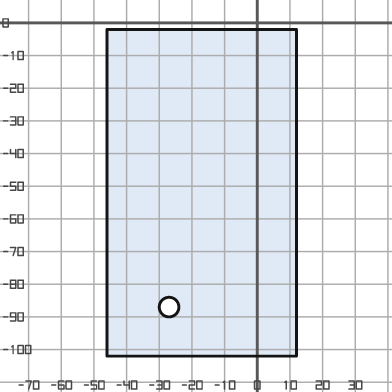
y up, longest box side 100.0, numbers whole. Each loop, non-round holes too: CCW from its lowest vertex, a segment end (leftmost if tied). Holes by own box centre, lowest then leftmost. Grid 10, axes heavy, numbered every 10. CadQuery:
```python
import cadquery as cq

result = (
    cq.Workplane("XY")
    .moveTo(-46.0, -102.0)
    .lineTo(12.0, -102.0)
    .lineTo(12.0, -2.0)
    .lineTo(-46.0, -2.0)
    .close()
    .moveTo(-27.0, -87.0)
    .circle(3.0)
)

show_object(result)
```